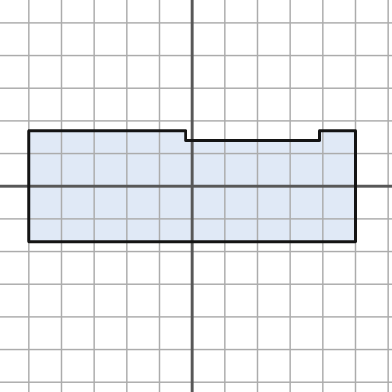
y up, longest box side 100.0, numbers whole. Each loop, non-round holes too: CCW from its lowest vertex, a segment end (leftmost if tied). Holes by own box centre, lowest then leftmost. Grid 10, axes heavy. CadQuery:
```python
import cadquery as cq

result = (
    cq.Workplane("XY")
    .moveTo(-50.0, -17.0)
    .lineTo(50.0, -17.0)
    .lineTo(50.0, 17.0)
    .lineTo(39.0, 17.0)
    .lineTo(39.0, 14.0)
    .lineTo(-2.0, 14.0)
    .lineTo(-2.0, 17.0)
    .lineTo(-50.0, 17.0)
    .close()
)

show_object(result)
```